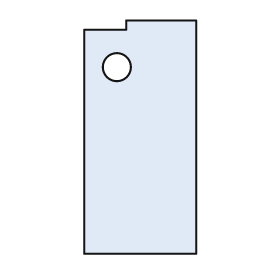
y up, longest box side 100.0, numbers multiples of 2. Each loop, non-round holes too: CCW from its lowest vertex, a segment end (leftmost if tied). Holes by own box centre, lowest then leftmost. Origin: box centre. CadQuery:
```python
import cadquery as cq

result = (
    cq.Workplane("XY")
    .moveTo(-24.0, -50.0)
    .lineTo(24.0, -50.0)
    .lineTo(24.0, 50.0)
    .lineTo(-6.0, 50.0)
    .lineTo(-6.0, 46.0)
    .lineTo(-24.0, 46.0)
    .close()
    .moveTo(-10.0, 30.0)
    .circle(6.0)
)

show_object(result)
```